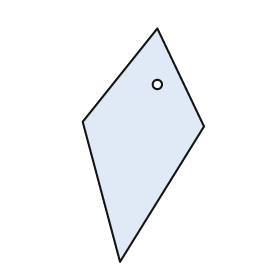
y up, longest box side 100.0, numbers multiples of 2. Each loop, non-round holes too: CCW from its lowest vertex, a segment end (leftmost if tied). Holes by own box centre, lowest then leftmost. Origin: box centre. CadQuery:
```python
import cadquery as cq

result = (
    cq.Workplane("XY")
    .moveTo(-10.0, -50.0)
    .lineTo(26.0, 8.0)
    .lineTo(6.0, 50.0)
    .lineTo(-26.0, 10.0)
    .close()
    .moveTo(6.0, 26.0)
    .circle(2.0)
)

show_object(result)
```